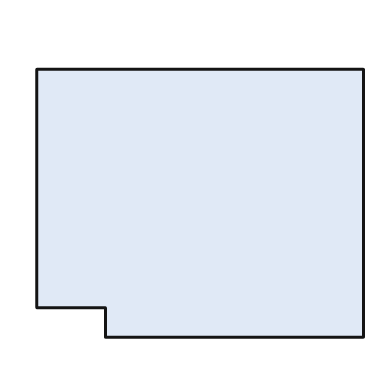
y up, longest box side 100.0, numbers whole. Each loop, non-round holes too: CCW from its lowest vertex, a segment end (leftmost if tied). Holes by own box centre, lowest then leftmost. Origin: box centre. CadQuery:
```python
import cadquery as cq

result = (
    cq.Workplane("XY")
    .moveTo(-29.0, -41.0)
    .lineTo(50.0, -41.0)
    .lineTo(50.0, 41.0)
    .lineTo(-50.0, 41.0)
    .lineTo(-50.0, -32.0)
    .lineTo(-29.0, -32.0)
    .close()
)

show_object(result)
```